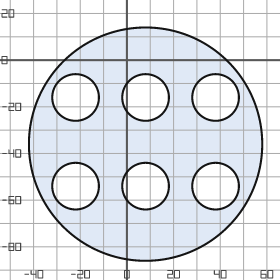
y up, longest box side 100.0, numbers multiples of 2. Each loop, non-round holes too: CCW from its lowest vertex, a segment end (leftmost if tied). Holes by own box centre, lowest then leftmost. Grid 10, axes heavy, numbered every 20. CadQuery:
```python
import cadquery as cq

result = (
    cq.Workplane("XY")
    .moveTo(8.0, -36.0)
    .circle(50.0)
    .moveTo(-22.0, -54.0)
    .circle(10.0)
    .moveTo(8.0, -54.0)
    .circle(10.0)
    .moveTo(38.0, -54.0)
    .circle(10.0)
    .moveTo(-22.0, -16.0)
    .circle(10.0)
    .moveTo(8.0, -16.0)
    .circle(10.0)
    .moveTo(38.0, -16.0)
    .circle(10.0)
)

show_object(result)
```